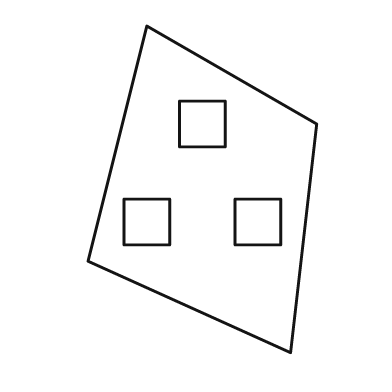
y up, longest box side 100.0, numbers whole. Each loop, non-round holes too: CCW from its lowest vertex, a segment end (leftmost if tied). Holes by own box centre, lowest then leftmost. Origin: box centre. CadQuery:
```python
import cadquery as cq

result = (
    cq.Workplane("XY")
    .moveTo(27.0, -50.0)
    .lineTo(35.0, 20.0)
    .lineTo(-17.0, 50.0)
    .lineTo(-35.0, -22.0)
    .close()
    .moveTo(-24.0, -17.0)
    .lineTo(-10.0, -17.0)
    .lineTo(-10.0, -3.0)
    .lineTo(-24.0, -3.0)
    .close()
    .moveTo(10.0, -17.0)
    .lineTo(24.0, -17.0)
    .lineTo(24.0, -3.0)
    .lineTo(10.0, -3.0)
    .close()
    .moveTo(-7.0, 13.0)
    .lineTo(7.0, 13.0)
    .lineTo(7.0, 27.0)
    .lineTo(-7.0, 27.0)
    .close()
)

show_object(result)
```